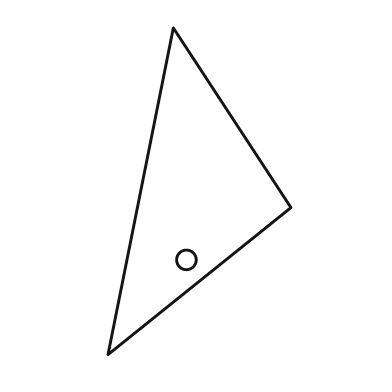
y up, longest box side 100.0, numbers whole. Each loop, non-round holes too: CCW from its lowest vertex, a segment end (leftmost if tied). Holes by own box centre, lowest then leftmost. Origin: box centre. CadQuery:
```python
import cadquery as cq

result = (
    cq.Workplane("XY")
    .moveTo(-28.0, -50.0)
    .lineTo(28.0, -5.0)
    .lineTo(-8.0, 50.0)
    .close()
    .moveTo(-4.0, -21.0)
    .circle(3.0)
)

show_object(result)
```